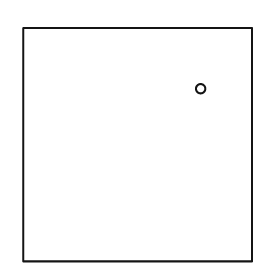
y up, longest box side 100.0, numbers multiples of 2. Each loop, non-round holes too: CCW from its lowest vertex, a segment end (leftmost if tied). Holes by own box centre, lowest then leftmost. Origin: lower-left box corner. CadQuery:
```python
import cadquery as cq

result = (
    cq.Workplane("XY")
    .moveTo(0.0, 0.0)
    .lineTo(98.0, 0.0)
    .lineTo(98.0, 100.0)
    .lineTo(0.0, 100.0)
    .close()
    .moveTo(76.0, 74.0)
    .circle(2.0)
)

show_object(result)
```